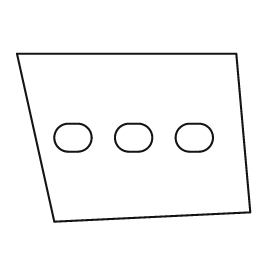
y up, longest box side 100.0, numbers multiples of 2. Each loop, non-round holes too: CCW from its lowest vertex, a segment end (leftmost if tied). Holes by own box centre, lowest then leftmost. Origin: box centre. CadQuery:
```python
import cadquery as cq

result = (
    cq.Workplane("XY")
    .moveTo(-34.0, -36.0)
    .lineTo(50.0, -32.0)
    .lineTo(44.0, 36.0)
    .lineTo(-50.0, 36.0)
    .close()
    .moveTo(-28.0, -6.0)
    .lineTo(-24.0, -6.0)
    .threePointArc((-18.0, 0.0), (-24.0, 6.0))
    .lineTo(-28.0, 6.0)
    .threePointArc((-34.0, 0.0), (-28.0, -6.0))
    .close()
    .moveTo(-2.0, -6.0)
    .lineTo(2.0, -6.0)
    .threePointArc((8.0, 0.0), (2.0, 6.0))
    .lineTo(-2.0, 6.0)
    .threePointArc((-8.0, 0.0), (-2.0, -6.0))
    .close()
    .moveTo(24.0, -6.0)
    .lineTo(28.0, -6.0)
    .threePointArc((34.0, 0.0), (28.0, 6.0))
    .lineTo(24.0, 6.0)
    .threePointArc((18.0, 0.0), (24.0, -6.0))
    .close()
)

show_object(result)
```